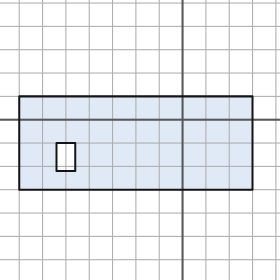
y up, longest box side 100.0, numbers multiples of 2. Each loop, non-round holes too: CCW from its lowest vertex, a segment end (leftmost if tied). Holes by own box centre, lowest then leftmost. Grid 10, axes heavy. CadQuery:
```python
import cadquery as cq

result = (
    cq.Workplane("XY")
    .moveTo(-70.0, -30.0)
    .lineTo(30.0, -30.0)
    .lineTo(30.0, 10.0)
    .lineTo(-70.0, 10.0)
    .close()
    .moveTo(-54.0, -22.0)
    .lineTo(-46.0, -22.0)
    .lineTo(-46.0, -10.0)
    .lineTo(-54.0, -10.0)
    .close()
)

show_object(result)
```